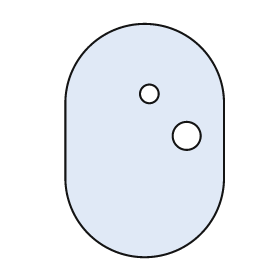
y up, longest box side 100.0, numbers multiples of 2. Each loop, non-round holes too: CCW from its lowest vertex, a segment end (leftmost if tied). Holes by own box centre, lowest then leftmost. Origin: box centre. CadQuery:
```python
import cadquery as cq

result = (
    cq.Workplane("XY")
    .moveTo(-34.0, -16.0)
    .threePointArc((0.0, -50.0), (34.0, -16.0))
    .lineTo(34.0, 16.0)
    .threePointArc((0.0, 50.0), (-34.0, 16.0))
    .close()
    .moveTo(18.0, 2.0)
    .circle(6.0)
    .moveTo(2.0, 20.0)
    .circle(4.0)
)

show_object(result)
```